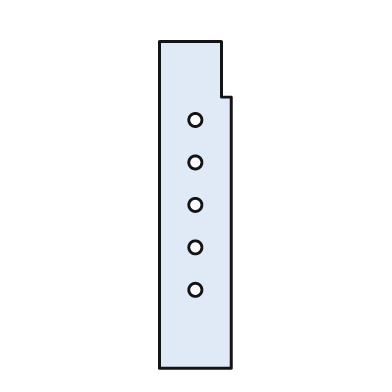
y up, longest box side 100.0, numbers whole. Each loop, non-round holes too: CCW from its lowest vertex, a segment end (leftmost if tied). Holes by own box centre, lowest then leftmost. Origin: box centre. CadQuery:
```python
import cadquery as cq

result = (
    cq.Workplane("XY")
    .moveTo(-11.0, -50.0)
    .lineTo(11.0, -50.0)
    .lineTo(11.0, 33.0)
    .lineTo(8.0, 33.0)
    .lineTo(8.0, 50.0)
    .lineTo(-11.0, 50.0)
    .close()
    .moveTo(0.0, -26.0)
    .circle(2.0)
    .moveTo(0.0, -13.0)
    .circle(2.0)
    .moveTo(0.0, 0.0)
    .circle(2.0)
    .moveTo(0.0, 13.0)
    .circle(2.0)
    .moveTo(0.0, 26.0)
    .circle(2.0)
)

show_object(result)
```